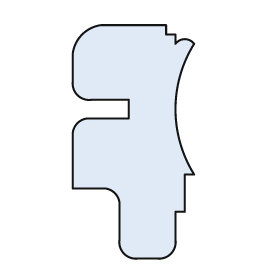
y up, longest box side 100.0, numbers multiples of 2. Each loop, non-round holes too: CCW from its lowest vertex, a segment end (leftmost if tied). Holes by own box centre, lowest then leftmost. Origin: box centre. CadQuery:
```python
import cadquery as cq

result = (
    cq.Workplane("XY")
    .moveTo(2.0, -50.0)
    .lineTo(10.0, -50.0)
    .threePointArc((16.0, -48.0), (18.0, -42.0))
    .lineTo(18.0, -30.0)
    .lineTo(22.0, -30.0)
    .lineTo(22.0, -14.0)
    .lineTo(26.0, -14.0)
    .threePointArc((18.0, 14.0), (26.0, 42.0))
    .threePointArc((22.0, 44.0), (18.0, 42.0))
    .lineTo(18.0, 46.0)
    .lineTo(14.0, 46.0)
    .lineTo(14.0, 50.0)
    .lineTo(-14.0, 50.0)
    .threePointArc((-22.0, 46.0), (-26.0, 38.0))
    .lineTo(-26.0, 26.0)
    .threePointArc((-24.0, 20.0), (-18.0, 18.0))
    .lineTo(-2.0, 18.0)
    .lineTo(-2.0, 10.0)
    .lineTo(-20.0, 10.0)
    .threePointArc((-24.0, 8.0), (-26.0, 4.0))
    .lineTo(-26.0, -20.0)
    .lineTo(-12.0, -20.0)
    .threePointArc((-8.0, -22.0), (-6.0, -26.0))
    .lineTo(-6.0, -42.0)
    .threePointArc((-4.0, -48.0), (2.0, -50.0))
    .close()
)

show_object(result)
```